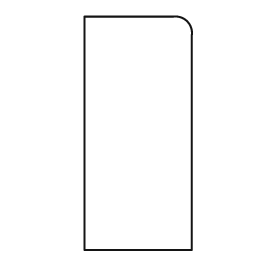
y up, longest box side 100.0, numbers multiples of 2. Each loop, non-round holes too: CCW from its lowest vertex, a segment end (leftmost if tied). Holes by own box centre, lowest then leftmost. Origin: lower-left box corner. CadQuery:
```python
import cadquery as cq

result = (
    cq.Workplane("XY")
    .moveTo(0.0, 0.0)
    .lineTo(46.0, 0.0)
    .lineTo(46.0, 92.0)
    .threePointArc((44.0, 98.0), (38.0, 100.0))
    .lineTo(0.0, 100.0)
    .close()
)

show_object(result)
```